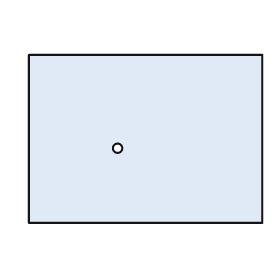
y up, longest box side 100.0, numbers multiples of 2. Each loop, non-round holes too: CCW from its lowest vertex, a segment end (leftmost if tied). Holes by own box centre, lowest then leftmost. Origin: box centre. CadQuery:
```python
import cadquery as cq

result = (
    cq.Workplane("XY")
    .moveTo(-50.0, -36.0)
    .lineTo(50.0, -36.0)
    .lineTo(50.0, 36.0)
    .lineTo(-50.0, 36.0)
    .close()
    .moveTo(-12.0, -4.0)
    .circle(2.0)
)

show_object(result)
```